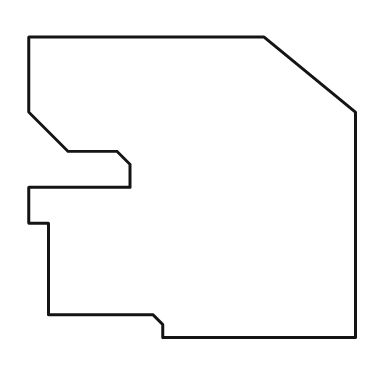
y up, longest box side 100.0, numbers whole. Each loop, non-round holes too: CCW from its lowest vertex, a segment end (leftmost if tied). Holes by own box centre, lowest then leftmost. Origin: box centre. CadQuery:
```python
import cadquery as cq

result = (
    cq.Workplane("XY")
    .moveTo(-9.0, -46.0)
    .lineTo(50.0, -46.0)
    .lineTo(50.0, 23.0)
    .lineTo(22.0, 46.0)
    .lineTo(-50.0, 46.0)
    .lineTo(-50.0, 23.0)
    .lineTo(-38.0, 11.0)
    .lineTo(-23.0, 11.0)
    .lineTo(-19.0, 7.0)
    .lineTo(-19.0, 0.0)
    .lineTo(-50.0, 0.0)
    .lineTo(-50.0, -11.0)
    .lineTo(-44.0, -11.0)
    .lineTo(-44.0, -39.0)
    .lineTo(-12.0, -39.0)
    .lineTo(-9.0, -42.0)
    .close()
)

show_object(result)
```